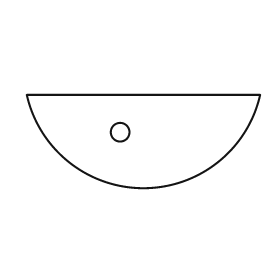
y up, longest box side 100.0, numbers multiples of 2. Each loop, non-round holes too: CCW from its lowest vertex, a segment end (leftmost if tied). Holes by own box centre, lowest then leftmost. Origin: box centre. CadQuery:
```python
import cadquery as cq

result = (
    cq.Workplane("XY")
    .moveTo(-50.0, 20.0)
    .threePointArc((0.0, -20.0), (50.0, 20.0))
    .close()
    .moveTo(-10.0, 4.0)
    .circle(4.0)
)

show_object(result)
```